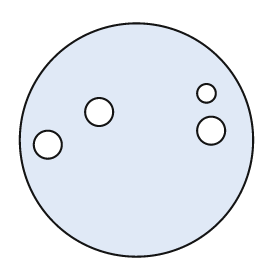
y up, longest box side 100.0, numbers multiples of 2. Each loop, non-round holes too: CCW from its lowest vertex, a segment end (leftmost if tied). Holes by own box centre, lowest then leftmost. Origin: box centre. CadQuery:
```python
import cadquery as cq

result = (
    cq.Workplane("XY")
    .moveTo(0.0, 0.0)
    .circle(50.0)
    .moveTo(-38.0, -2.0)
    .circle(6.0)
    .moveTo(32.0, 4.0)
    .circle(6.0)
    .moveTo(-16.0, 12.0)
    .circle(6.0)
    .moveTo(30.0, 20.0)
    .circle(4.0)
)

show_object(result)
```